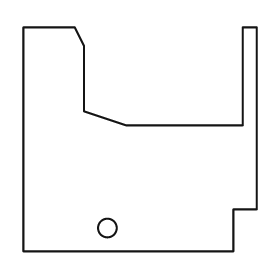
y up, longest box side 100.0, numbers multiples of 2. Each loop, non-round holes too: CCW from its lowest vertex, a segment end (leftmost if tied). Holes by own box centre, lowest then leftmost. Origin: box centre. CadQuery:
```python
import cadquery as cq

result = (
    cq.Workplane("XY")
    .moveTo(-50.0, -48.0)
    .lineTo(40.0, -48.0)
    .lineTo(40.0, -30.0)
    .lineTo(50.0, -30.0)
    .lineTo(50.0, 48.0)
    .lineTo(44.0, 48.0)
    .lineTo(44.0, 6.0)
    .lineTo(-6.0, 6.0)
    .lineTo(-24.0, 12.0)
    .lineTo(-24.0, 40.0)
    .lineTo(-28.0, 48.0)
    .lineTo(-50.0, 48.0)
    .close()
    .moveTo(-14.0, -38.0)
    .circle(4.0)
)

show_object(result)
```